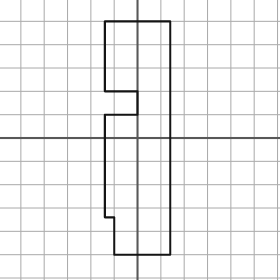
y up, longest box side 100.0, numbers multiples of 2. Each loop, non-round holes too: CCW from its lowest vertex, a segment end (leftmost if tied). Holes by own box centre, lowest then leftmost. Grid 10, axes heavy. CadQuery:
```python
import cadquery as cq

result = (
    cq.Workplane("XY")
    .moveTo(-10.0, -50.0)
    .lineTo(14.0, -50.0)
    .lineTo(14.0, 50.0)
    .lineTo(-14.0, 50.0)
    .lineTo(-14.0, 20.0)
    .lineTo(0.0, 20.0)
    .lineTo(0.0, 10.0)
    .lineTo(-14.0, 10.0)
    .lineTo(-14.0, -34.0)
    .lineTo(-10.0, -34.0)
    .close()
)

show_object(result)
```